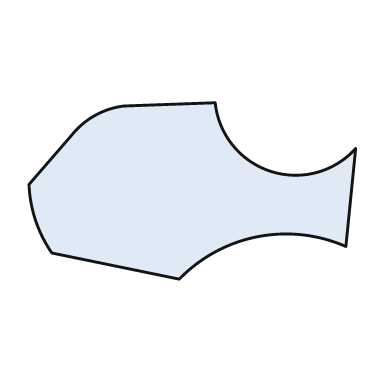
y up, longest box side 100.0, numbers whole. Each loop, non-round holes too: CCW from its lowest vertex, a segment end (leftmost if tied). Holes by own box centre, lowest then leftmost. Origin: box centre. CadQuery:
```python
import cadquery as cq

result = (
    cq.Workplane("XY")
    .moveTo(-4.0, -27.0)
    .threePointArc((20.0, -14.0), (47.0, -17.0))
    .lineTo(50.0, 13.0)
    .threePointArc((24.0, 6.0), (7.0, 27.0))
    .lineTo(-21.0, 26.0)
    .threePointArc((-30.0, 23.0), (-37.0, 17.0))
    .lineTo(-50.0, 2.0)
    .threePointArc((-48.0, -9.0), (-43.0, -19.0))
    .close()
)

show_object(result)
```